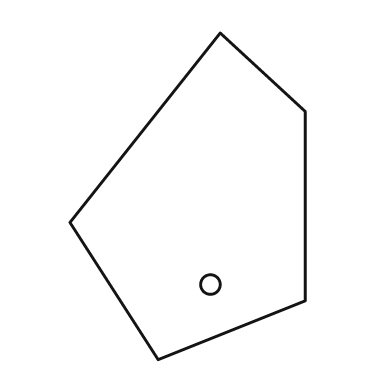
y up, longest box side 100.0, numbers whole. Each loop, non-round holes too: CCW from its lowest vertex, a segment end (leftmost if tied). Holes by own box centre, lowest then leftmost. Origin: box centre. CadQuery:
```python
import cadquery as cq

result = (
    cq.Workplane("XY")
    .moveTo(-9.0, -50.0)
    .lineTo(36.0, -32.0)
    .lineTo(36.0, 26.0)
    .lineTo(10.0, 50.0)
    .lineTo(-36.0, -8.0)
    .close()
    .moveTo(7.0, -27.0)
    .circle(3.0)
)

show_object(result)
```